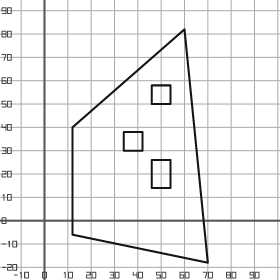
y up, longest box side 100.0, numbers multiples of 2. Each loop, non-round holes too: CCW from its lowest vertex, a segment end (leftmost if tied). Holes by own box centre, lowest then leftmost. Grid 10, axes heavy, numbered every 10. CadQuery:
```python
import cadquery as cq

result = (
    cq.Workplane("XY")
    .moveTo(70.0, -18.0)
    .lineTo(60.0, 82.0)
    .lineTo(12.0, 40.0)
    .lineTo(12.0, -6.0)
    .close()
    .moveTo(46.0, 14.0)
    .lineTo(54.0, 14.0)
    .lineTo(54.0, 26.0)
    .lineTo(46.0, 26.0)
    .close()
    .moveTo(34.0, 30.0)
    .lineTo(42.0, 30.0)
    .lineTo(42.0, 38.0)
    .lineTo(34.0, 38.0)
    .close()
    .moveTo(46.0, 50.0)
    .lineTo(54.0, 50.0)
    .lineTo(54.0, 58.0)
    .lineTo(46.0, 58.0)
    .close()
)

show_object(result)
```